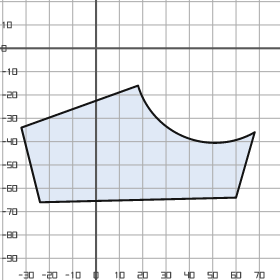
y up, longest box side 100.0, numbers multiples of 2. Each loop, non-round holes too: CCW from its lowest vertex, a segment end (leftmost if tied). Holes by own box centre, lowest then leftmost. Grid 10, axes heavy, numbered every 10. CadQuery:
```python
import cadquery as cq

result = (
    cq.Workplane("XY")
    .moveTo(-24.0, -66.0)
    .lineTo(60.0, -64.0)
    .lineTo(68.0, -36.0)
    .threePointArc((38.0, -38.0), (18.0, -16.0))
    .lineTo(-32.0, -34.0)
    .close()
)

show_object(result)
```